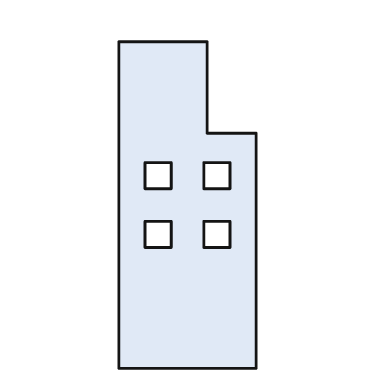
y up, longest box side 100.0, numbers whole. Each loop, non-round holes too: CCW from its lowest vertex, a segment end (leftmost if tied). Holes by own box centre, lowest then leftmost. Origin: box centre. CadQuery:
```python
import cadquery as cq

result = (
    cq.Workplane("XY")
    .moveTo(-21.0, -50.0)
    .lineTo(21.0, -50.0)
    .lineTo(21.0, 22.0)
    .lineTo(6.0, 22.0)
    .lineTo(6.0, 50.0)
    .lineTo(-21.0, 50.0)
    .close()
    .moveTo(-13.0, -13.0)
    .lineTo(-5.0, -13.0)
    .lineTo(-5.0, -5.0)
    .lineTo(-13.0, -5.0)
    .close()
    .moveTo(5.0, -13.0)
    .lineTo(13.0, -13.0)
    .lineTo(13.0, -5.0)
    .lineTo(5.0, -5.0)
    .close()
    .moveTo(-13.0, 5.0)
    .lineTo(-5.0, 5.0)
    .lineTo(-5.0, 13.0)
    .lineTo(-13.0, 13.0)
    .close()
    .moveTo(5.0, 5.0)
    .lineTo(13.0, 5.0)
    .lineTo(13.0, 13.0)
    .lineTo(5.0, 13.0)
    .close()
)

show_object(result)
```